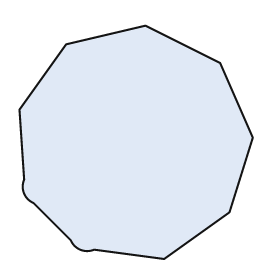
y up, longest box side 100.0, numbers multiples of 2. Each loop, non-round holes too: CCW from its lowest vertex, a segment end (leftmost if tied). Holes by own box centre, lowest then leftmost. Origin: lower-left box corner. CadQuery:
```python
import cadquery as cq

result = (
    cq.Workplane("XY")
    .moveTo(62.0, 0.0)
    .lineTo(90.0, 20.0)
    .lineTo(100.0, 52.0)
    .lineTo(86.0, 84.0)
    .lineTo(54.0, 100.0)
    .lineTo(20.0, 92.0)
    .lineTo(0.0, 64.0)
    .lineTo(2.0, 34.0)
    .threePointArc((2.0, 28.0), (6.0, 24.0))
    .lineTo(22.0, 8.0)
    .threePointArc((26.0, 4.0), (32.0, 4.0))
    .close()
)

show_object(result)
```